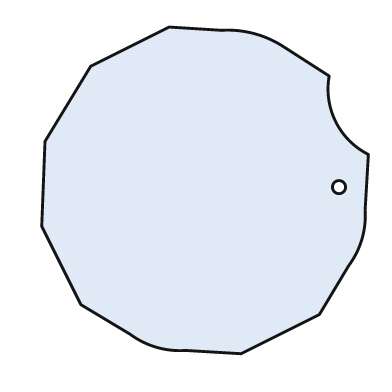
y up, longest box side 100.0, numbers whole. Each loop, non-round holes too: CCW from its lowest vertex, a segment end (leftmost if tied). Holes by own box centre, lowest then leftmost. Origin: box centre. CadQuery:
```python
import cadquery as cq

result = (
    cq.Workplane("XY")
    .moveTo(11.0, -50.0)
    .lineTo(35.0, -38.0)
    .lineTo(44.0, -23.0)
    .threePointArc((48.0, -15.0), (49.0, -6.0))
    .lineTo(50.0, 11.0)
    .threePointArc((40.0, 21.0), (38.0, 35.0))
    .lineTo(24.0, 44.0)
    .threePointArc((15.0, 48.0), (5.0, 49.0))
    .lineTo(-11.0, 50.0)
    .lineTo(-35.0, 38.0)
    .lineTo(-49.0, 15.0)
    .lineTo(-50.0, -11.0)
    .lineTo(-38.0, -35.0)
    .lineTo(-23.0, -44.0)
    .threePointArc((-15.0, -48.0), (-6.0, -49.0))
    .close()
    .moveTo(41.0, 1.0)
    .circle(2.0)
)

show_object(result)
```